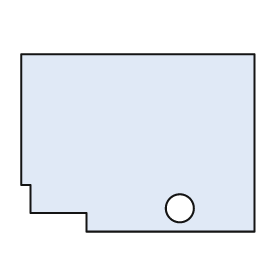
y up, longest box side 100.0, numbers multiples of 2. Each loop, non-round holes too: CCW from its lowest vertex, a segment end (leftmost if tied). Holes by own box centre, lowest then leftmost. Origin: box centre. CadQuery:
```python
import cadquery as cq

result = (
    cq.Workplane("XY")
    .moveTo(-22.0, -38.0)
    .lineTo(50.0, -38.0)
    .lineTo(50.0, 38.0)
    .lineTo(-50.0, 38.0)
    .lineTo(-50.0, -18.0)
    .lineTo(-46.0, -18.0)
    .lineTo(-46.0, -30.0)
    .lineTo(-22.0, -30.0)
    .close()
    .moveTo(18.0, -28.0)
    .circle(6.0)
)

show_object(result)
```